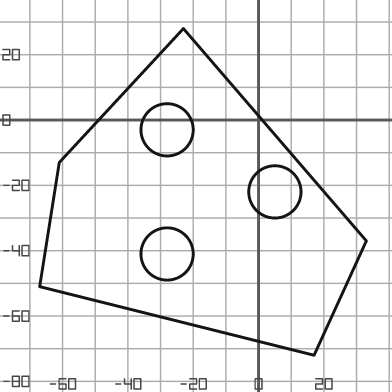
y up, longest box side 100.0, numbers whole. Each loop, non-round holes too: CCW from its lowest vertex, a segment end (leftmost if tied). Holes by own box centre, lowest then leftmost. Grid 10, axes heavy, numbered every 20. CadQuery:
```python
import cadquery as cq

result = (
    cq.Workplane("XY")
    .moveTo(17.0, -72.0)
    .lineTo(33.0, -37.0)
    .lineTo(-23.0, 28.0)
    .lineTo(-61.0, -13.0)
    .lineTo(-67.0, -51.0)
    .close()
    .moveTo(-28.0, -41.0)
    .circle(8.0)
    .moveTo(5.0, -22.0)
    .circle(8.0)
    .moveTo(-28.0, -3.0)
    .circle(8.0)
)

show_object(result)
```